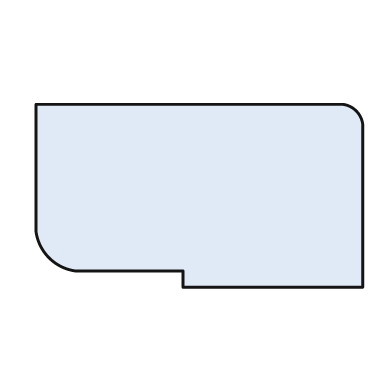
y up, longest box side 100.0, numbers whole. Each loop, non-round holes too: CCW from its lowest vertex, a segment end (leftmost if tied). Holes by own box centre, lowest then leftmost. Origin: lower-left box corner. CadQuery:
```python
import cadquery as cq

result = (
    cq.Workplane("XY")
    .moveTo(45.0, 0.0)
    .lineTo(100.0, 0.0)
    .lineTo(100.0, 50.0)
    .threePointArc((98.0, 54.0), (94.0, 56.0))
    .lineTo(0.0, 56.0)
    .lineTo(0.0, 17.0)
    .threePointArc((4.0, 9.0), (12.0, 5.0))
    .lineTo(45.0, 5.0)
    .close()
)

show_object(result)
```